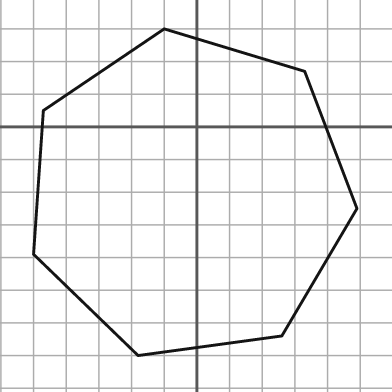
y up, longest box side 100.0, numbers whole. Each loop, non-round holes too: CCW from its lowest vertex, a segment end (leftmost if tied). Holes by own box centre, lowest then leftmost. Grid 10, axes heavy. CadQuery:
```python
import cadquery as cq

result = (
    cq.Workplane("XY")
    .moveTo(-18.0, -70.0)
    .lineTo(26.0, -64.0)
    .lineTo(49.0, -25.0)
    .lineTo(33.0, 17.0)
    .lineTo(-10.0, 30.0)
    .lineTo(-47.0, 5.0)
    .lineTo(-50.0, -39.0)
    .close()
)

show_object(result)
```